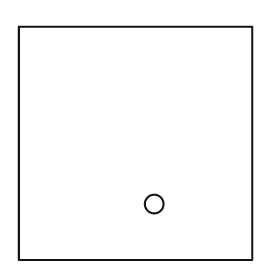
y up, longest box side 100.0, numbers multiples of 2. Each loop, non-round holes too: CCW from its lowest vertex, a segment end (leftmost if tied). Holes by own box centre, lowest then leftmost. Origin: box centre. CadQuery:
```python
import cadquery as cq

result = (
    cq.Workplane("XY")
    .moveTo(-50.0, -50.0)
    .lineTo(50.0, -50.0)
    .lineTo(50.0, 50.0)
    .lineTo(-50.0, 50.0)
    .close()
    .moveTo(8.0, -26.0)
    .circle(4.0)
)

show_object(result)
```